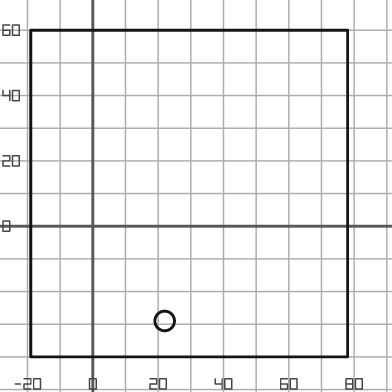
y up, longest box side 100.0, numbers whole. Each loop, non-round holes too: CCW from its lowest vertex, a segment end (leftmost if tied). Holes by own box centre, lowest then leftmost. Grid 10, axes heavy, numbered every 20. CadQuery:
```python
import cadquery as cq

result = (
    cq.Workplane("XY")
    .moveTo(-19.0, -40.0)
    .lineTo(78.0, -40.0)
    .lineTo(78.0, 60.0)
    .lineTo(-19.0, 60.0)
    .close()
    .moveTo(22.0, -29.0)
    .circle(3.0)
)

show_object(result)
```